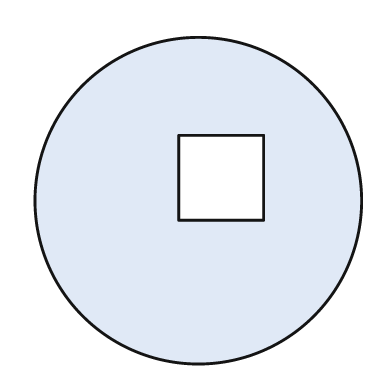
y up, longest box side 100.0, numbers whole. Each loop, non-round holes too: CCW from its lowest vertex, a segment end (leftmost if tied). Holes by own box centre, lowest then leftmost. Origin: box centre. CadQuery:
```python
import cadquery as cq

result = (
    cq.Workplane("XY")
    .moveTo(0.0, 0.0)
    .circle(50.0)
    .moveTo(-6.0, -6.0)
    .lineTo(20.0, -6.0)
    .lineTo(20.0, 20.0)
    .lineTo(-6.0, 20.0)
    .close()
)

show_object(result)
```